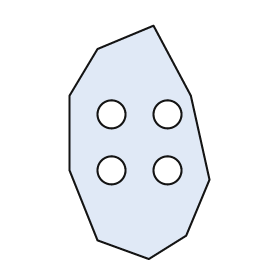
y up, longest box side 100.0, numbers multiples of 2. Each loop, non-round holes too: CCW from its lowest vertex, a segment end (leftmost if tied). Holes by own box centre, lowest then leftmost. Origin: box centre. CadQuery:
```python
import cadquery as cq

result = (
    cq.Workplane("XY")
    .moveTo(4.0, -50.0)
    .lineTo(20.0, -40.0)
    .lineTo(30.0, -16.0)
    .lineTo(22.0, 20.0)
    .lineTo(6.0, 50.0)
    .lineTo(-18.0, 40.0)
    .lineTo(-30.0, 20.0)
    .lineTo(-30.0, -12.0)
    .lineTo(-18.0, -42.0)
    .close()
    .moveTo(-12.0, -12.0)
    .circle(6.0)
    .moveTo(12.0, -12.0)
    .circle(6.0)
    .moveTo(-12.0, 12.0)
    .circle(6.0)
    .moveTo(12.0, 12.0)
    .circle(6.0)
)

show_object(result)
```